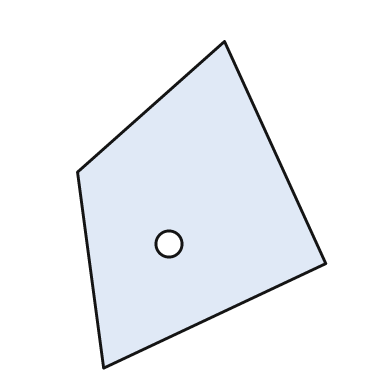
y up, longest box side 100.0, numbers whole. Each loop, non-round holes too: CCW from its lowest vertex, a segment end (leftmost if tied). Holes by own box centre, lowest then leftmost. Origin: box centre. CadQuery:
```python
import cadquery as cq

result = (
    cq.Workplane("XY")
    .moveTo(-30.0, -50.0)
    .lineTo(38.0, -18.0)
    .lineTo(7.0, 50.0)
    .lineTo(-38.0, 10.0)
    .close()
    .moveTo(-10.0, -12.0)
    .circle(4.0)
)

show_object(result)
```